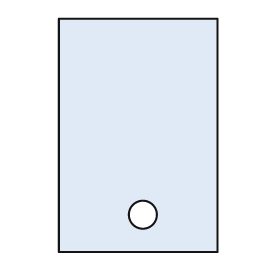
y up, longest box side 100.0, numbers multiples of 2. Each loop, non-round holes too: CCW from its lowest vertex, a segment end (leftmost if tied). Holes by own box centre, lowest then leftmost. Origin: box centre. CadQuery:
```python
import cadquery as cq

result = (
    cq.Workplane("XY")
    .moveTo(-34.0, -50.0)
    .lineTo(34.0, -50.0)
    .lineTo(34.0, 50.0)
    .lineTo(-34.0, 50.0)
    .close()
    .moveTo(2.0, -34.0)
    .circle(6.0)
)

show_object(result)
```